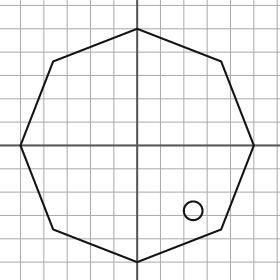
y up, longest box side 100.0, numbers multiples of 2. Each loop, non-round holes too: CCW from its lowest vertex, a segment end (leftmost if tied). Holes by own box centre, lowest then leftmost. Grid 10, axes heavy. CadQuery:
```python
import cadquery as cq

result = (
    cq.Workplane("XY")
    .moveTo(0.0, -50.0)
    .lineTo(36.0, -36.0)
    .lineTo(50.0, 0.0)
    .lineTo(36.0, 36.0)
    .lineTo(0.0, 50.0)
    .lineTo(-36.0, 36.0)
    .lineTo(-50.0, 0.0)
    .lineTo(-36.0, -36.0)
    .close()
    .moveTo(24.0, -28.0)
    .circle(4.0)
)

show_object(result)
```